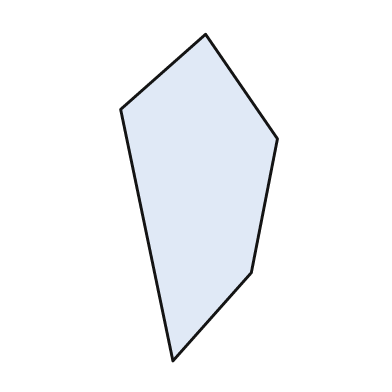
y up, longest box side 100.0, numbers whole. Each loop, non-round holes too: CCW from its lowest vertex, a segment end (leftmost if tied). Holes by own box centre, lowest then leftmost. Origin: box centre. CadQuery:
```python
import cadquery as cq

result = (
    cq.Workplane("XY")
    .moveTo(-8.0, -50.0)
    .lineTo(16.0, -23.0)
    .lineTo(24.0, 18.0)
    .lineTo(2.0, 50.0)
    .lineTo(-24.0, 27.0)
    .close()
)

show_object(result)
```